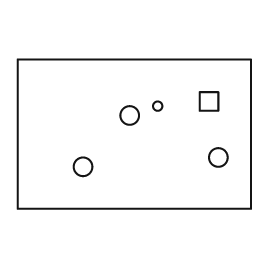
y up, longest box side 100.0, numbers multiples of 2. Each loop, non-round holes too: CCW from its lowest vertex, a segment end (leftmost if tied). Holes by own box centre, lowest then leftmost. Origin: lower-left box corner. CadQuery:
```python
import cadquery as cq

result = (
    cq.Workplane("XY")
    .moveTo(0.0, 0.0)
    .lineTo(100.0, 0.0)
    .lineTo(100.0, 64.0)
    .lineTo(0.0, 64.0)
    .close()
    .moveTo(28.0, 18.0)
    .circle(4.0)
    .moveTo(86.0, 22.0)
    .circle(4.0)
    .moveTo(48.0, 40.0)
    .circle(4.0)
    .moveTo(60.0, 44.0)
    .circle(2.0)
    .moveTo(78.0, 42.0)
    .lineTo(86.0, 42.0)
    .lineTo(86.0, 50.0)
    .lineTo(78.0, 50.0)
    .close()
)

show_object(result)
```